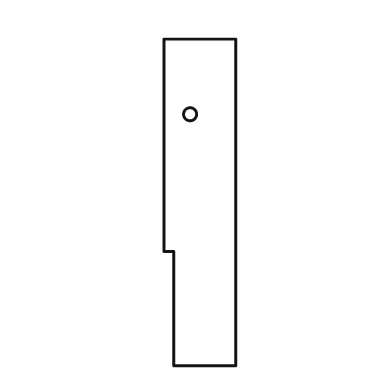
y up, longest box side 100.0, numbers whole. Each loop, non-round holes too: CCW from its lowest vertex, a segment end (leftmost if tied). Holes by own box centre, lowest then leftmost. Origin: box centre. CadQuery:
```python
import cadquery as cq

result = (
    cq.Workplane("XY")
    .moveTo(-8.0, -50.0)
    .lineTo(11.0, -50.0)
    .lineTo(11.0, 50.0)
    .lineTo(-11.0, 50.0)
    .lineTo(-11.0, -15.0)
    .lineTo(-8.0, -15.0)
    .close()
    .moveTo(-3.0, 27.0)
    .circle(2.0)
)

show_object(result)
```